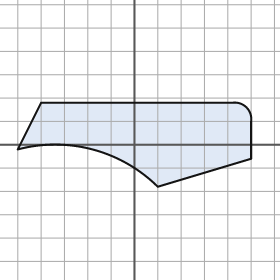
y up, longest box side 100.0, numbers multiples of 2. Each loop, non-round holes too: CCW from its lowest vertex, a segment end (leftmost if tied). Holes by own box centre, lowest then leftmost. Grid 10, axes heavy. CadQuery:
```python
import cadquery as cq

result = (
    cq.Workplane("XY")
    .moveTo(10.0, -18.0)
    .lineTo(50.0, -6.0)
    .lineTo(50.0, 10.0)
    .threePointArc((48.0, 16.0), (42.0, 18.0))
    .lineTo(-40.0, 18.0)
    .lineTo(-50.0, -2.0)
    .threePointArc((-18.0, -2.0), (10.0, -18.0))
    .close()
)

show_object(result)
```